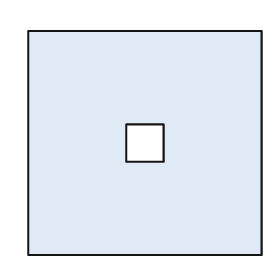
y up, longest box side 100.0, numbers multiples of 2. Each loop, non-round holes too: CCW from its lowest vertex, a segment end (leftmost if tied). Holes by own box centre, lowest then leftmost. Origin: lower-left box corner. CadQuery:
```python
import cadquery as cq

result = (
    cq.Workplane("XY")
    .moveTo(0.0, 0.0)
    .lineTo(100.0, 0.0)
    .lineTo(100.0, 96.0)
    .lineTo(0.0, 96.0)
    .close()
    .moveTo(42.0, 40.0)
    .lineTo(58.0, 40.0)
    .lineTo(58.0, 56.0)
    .lineTo(42.0, 56.0)
    .close()
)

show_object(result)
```